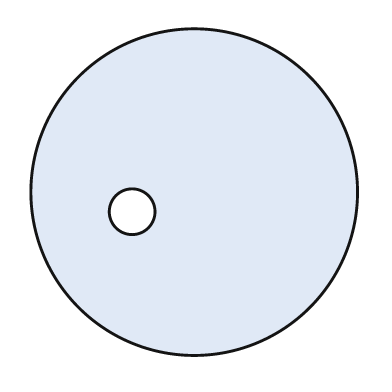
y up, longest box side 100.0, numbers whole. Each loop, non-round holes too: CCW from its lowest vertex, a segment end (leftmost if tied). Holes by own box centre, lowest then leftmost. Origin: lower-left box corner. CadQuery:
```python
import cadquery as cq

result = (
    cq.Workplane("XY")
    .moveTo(50.0, 50.0)
    .circle(50.0)
    .moveTo(31.0, 44.0)
    .circle(7.0)
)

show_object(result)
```